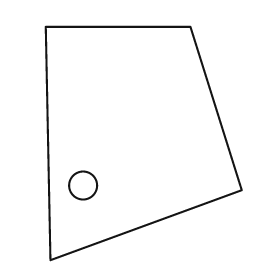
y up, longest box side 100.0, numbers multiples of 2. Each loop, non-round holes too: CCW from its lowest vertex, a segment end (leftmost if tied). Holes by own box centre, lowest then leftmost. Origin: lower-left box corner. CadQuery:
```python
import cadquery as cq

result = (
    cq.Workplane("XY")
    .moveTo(2.0, 0.0)
    .lineTo(84.0, 30.0)
    .lineTo(62.0, 100.0)
    .lineTo(0.0, 100.0)
    .close()
    .moveTo(16.0, 32.0)
    .circle(6.0)
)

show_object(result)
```